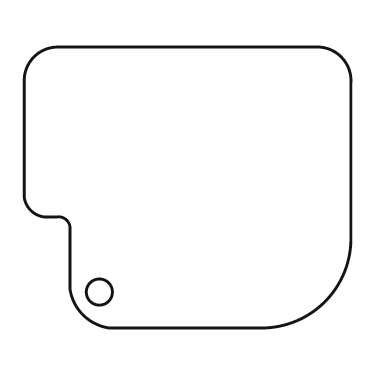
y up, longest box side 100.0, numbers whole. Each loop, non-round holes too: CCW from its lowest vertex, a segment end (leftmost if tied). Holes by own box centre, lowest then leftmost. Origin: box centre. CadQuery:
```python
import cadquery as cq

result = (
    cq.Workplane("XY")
    .moveTo(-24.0, -43.0)
    .lineTo(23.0, -43.0)
    .threePointArc((42.0, -35.0), (50.0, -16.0))
    .lineTo(50.0, 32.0)
    .threePointArc((47.0, 40.0), (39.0, 43.0))
    .lineTo(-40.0, 43.0)
    .threePointArc((-47.0, 40.0), (-50.0, 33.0))
    .lineTo(-50.0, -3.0)
    .threePointArc((-48.0, -7.0), (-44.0, -9.0))
    .lineTo(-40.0, -9.0)
    .threePointArc((-37.0, -10.0), (-36.0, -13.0))
    .lineTo(-36.0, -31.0)
    .threePointArc((-32.0, -39.0), (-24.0, -43.0))
    .close()
    .moveTo(-27.0, -32.0)
    .circle(4.0)
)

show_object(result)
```